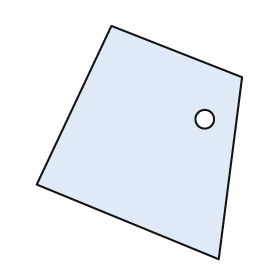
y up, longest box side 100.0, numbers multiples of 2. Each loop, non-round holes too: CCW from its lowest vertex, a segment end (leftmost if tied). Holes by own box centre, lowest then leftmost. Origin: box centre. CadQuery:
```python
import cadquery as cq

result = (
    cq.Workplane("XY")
    .moveTo(34.0, -50.0)
    .lineTo(44.0, 28.0)
    .lineTo(-12.0, 50.0)
    .lineTo(-44.0, -18.0)
    .close()
    .moveTo(28.0, 10.0)
    .circle(4.0)
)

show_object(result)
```